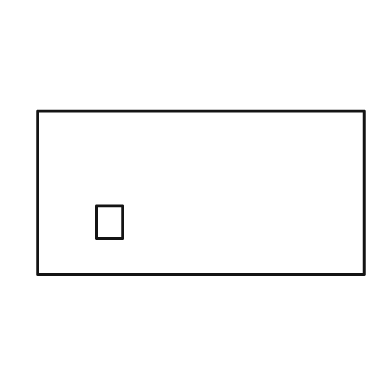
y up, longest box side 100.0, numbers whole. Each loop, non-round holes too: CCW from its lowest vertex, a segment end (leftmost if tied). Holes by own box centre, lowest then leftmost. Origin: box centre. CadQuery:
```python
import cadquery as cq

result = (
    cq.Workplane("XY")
    .moveTo(-50.0, -25.0)
    .lineTo(50.0, -25.0)
    .lineTo(50.0, 25.0)
    .lineTo(-50.0, 25.0)
    .close()
    .moveTo(-32.0, -14.0)
    .lineTo(-24.0, -14.0)
    .lineTo(-24.0, -4.0)
    .lineTo(-32.0, -4.0)
    .close()
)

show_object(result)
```